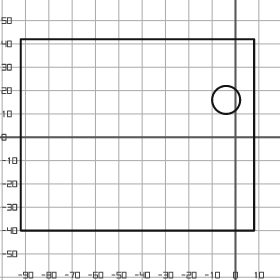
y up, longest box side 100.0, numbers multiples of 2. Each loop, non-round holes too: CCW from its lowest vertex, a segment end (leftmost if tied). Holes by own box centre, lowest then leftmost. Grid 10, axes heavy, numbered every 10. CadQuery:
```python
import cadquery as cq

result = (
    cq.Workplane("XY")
    .moveTo(-92.0, -40.0)
    .lineTo(8.0, -40.0)
    .lineTo(8.0, 42.0)
    .lineTo(-92.0, 42.0)
    .close()
    .moveTo(-4.0, 16.0)
    .circle(6.0)
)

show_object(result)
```